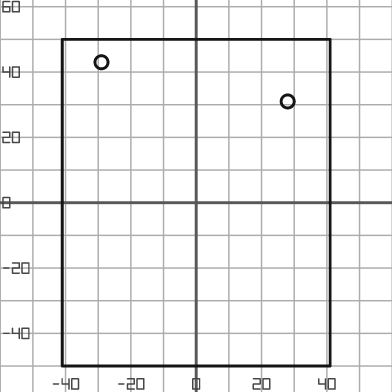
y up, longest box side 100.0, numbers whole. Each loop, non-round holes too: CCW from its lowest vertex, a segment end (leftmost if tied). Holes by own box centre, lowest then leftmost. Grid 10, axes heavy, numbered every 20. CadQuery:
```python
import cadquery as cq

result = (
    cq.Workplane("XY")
    .moveTo(-41.0, -50.0)
    .lineTo(41.0, -50.0)
    .lineTo(41.0, 50.0)
    .lineTo(-41.0, 50.0)
    .close()
    .moveTo(28.0, 31.0)
    .circle(2.0)
    .moveTo(-29.0, 43.0)
    .circle(2.0)
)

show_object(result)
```